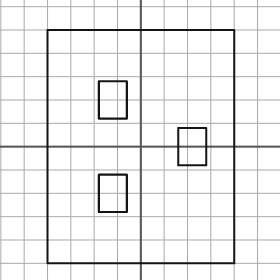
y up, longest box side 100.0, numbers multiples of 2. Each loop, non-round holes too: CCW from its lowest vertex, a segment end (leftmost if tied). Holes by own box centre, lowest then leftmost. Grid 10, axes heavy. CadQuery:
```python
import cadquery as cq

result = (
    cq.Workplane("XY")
    .moveTo(-40.0, -50.0)
    .lineTo(40.0, -50.0)
    .lineTo(40.0, 50.0)
    .lineTo(-40.0, 50.0)
    .close()
    .moveTo(-18.0, -28.0)
    .lineTo(-6.0, -28.0)
    .lineTo(-6.0, -12.0)
    .lineTo(-18.0, -12.0)
    .close()
    .moveTo(16.0, -8.0)
    .lineTo(28.0, -8.0)
    .lineTo(28.0, 8.0)
    .lineTo(16.0, 8.0)
    .close()
    .moveTo(-18.0, 12.0)
    .lineTo(-6.0, 12.0)
    .lineTo(-6.0, 28.0)
    .lineTo(-18.0, 28.0)
    .close()
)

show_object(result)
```